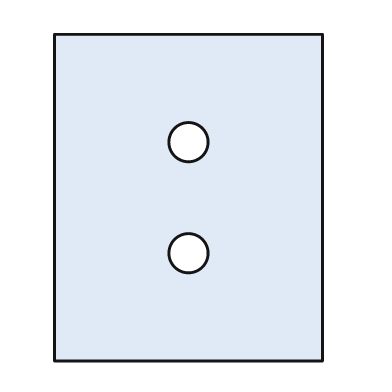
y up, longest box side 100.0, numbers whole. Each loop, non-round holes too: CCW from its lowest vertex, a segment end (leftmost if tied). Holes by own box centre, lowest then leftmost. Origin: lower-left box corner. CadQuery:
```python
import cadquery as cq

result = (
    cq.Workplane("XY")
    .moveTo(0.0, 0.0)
    .lineTo(82.0, 0.0)
    .lineTo(82.0, 100.0)
    .lineTo(0.0, 100.0)
    .close()
    .moveTo(41.0, 33.0)
    .circle(6.0)
    .moveTo(41.0, 67.0)
    .circle(6.0)
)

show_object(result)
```